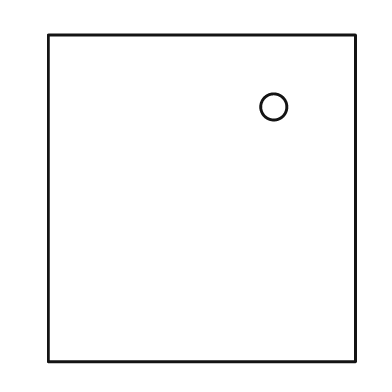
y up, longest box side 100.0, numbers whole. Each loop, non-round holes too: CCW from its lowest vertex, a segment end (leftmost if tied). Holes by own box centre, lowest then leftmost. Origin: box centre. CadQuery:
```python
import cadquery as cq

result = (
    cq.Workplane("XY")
    .moveTo(-47.0, -50.0)
    .lineTo(47.0, -50.0)
    .lineTo(47.0, 50.0)
    .lineTo(-47.0, 50.0)
    .close()
    .moveTo(22.0, 28.0)
    .circle(4.0)
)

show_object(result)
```